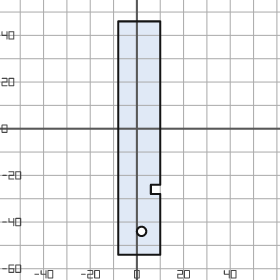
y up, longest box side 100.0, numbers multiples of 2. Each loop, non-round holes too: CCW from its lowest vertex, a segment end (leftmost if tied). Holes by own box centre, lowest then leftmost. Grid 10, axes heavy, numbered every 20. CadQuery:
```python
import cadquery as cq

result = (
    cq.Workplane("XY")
    .moveTo(-8.0, -54.0)
    .lineTo(10.0, -54.0)
    .lineTo(10.0, -28.0)
    .lineTo(6.0, -28.0)
    .lineTo(6.0, -24.0)
    .lineTo(10.0, -24.0)
    .lineTo(10.0, 46.0)
    .lineTo(-8.0, 46.0)
    .close()
    .moveTo(2.0, -44.0)
    .circle(2.0)
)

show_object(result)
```